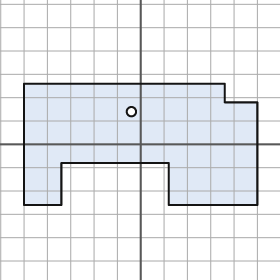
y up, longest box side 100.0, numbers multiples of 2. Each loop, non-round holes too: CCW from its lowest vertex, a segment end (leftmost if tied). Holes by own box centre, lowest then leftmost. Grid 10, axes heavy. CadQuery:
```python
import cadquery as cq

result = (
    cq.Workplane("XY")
    .moveTo(-50.0, -26.0)
    .lineTo(-34.0, -26.0)
    .lineTo(-34.0, -8.0)
    .lineTo(12.0, -8.0)
    .lineTo(12.0, -26.0)
    .lineTo(50.0, -26.0)
    .lineTo(50.0, 18.0)
    .lineTo(36.0, 18.0)
    .lineTo(36.0, 26.0)
    .lineTo(-50.0, 26.0)
    .close()
    .moveTo(-4.0, 14.0)
    .circle(2.0)
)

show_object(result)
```